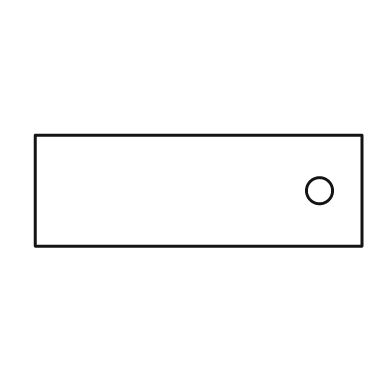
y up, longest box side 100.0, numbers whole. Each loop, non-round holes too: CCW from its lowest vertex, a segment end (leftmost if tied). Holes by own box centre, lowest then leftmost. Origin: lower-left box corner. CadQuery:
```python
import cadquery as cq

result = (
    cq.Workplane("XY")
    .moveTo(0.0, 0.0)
    .lineTo(100.0, 0.0)
    .lineTo(100.0, 34.0)
    .lineTo(0.0, 34.0)
    .close()
    .moveTo(87.0, 17.0)
    .circle(4.0)
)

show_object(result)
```